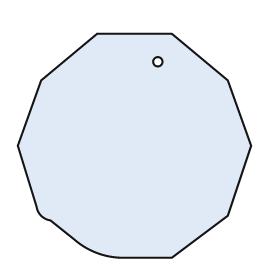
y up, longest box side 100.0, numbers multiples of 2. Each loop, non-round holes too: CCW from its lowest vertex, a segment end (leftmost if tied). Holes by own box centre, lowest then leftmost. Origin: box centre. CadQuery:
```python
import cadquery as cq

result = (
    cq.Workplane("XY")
    .moveTo(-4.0, -48.0)
    .lineTo(16.0, -48.0)
    .lineTo(40.0, -30.0)
    .lineTo(50.0, 0.0)
    .lineTo(40.0, 28.0)
    .lineTo(16.0, 48.0)
    .lineTo(-16.0, 48.0)
    .lineTo(-40.0, 28.0)
    .lineTo(-50.0, 0.0)
    .lineTo(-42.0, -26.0)
    .threePointArc((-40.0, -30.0), (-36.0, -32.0))
    .lineTo(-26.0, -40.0)
    .threePointArc((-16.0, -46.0), (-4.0, -48.0))
    .close()
    .moveTo(10.0, 36.0)
    .circle(2.0)
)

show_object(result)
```